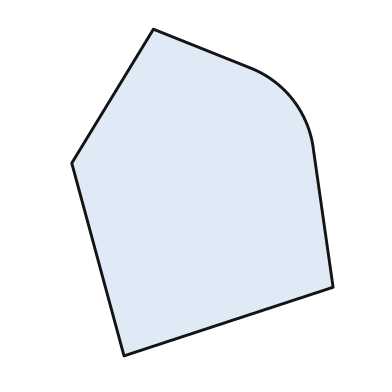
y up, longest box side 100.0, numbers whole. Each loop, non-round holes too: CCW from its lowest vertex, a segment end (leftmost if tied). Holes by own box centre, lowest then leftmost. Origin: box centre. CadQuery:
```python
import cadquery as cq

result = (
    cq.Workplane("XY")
    .moveTo(-24.0, -50.0)
    .lineTo(40.0, -29.0)
    .lineTo(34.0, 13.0)
    .threePointArc((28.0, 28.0), (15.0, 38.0))
    .lineTo(-15.0, 50.0)
    .lineTo(-40.0, 9.0)
    .close()
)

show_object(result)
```